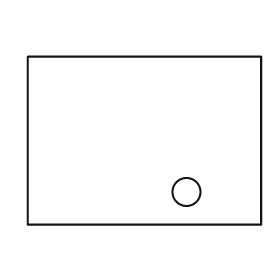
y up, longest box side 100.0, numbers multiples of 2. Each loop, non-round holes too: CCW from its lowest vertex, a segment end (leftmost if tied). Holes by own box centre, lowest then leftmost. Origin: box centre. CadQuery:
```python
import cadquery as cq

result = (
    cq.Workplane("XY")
    .moveTo(-50.0, -36.0)
    .lineTo(50.0, -36.0)
    .lineTo(50.0, 36.0)
    .lineTo(-50.0, 36.0)
    .close()
    .moveTo(18.0, -22.0)
    .circle(6.0)
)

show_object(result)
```